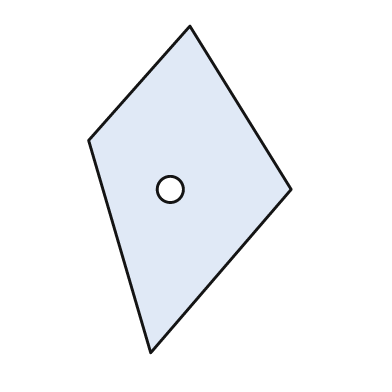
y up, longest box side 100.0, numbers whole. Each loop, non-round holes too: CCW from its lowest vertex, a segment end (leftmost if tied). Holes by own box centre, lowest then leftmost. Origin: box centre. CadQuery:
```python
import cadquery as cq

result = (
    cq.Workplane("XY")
    .moveTo(-12.0, -50.0)
    .lineTo(31.0, 0.0)
    .lineTo(0.0, 50.0)
    .lineTo(-31.0, 15.0)
    .close()
    .moveTo(-6.0, 0.0)
    .circle(4.0)
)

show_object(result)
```